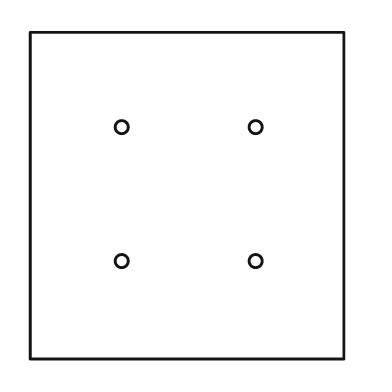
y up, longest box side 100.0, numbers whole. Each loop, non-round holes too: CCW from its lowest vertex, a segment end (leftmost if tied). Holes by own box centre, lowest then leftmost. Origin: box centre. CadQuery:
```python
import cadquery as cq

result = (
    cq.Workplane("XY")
    .moveTo(-48.0, -50.0)
    .lineTo(48.0, -50.0)
    .lineTo(48.0, 50.0)
    .lineTo(-48.0, 50.0)
    .close()
    .moveTo(-20.0, -20.0)
    .circle(2.0)
    .moveTo(21.0, -20.0)
    .circle(2.0)
    .moveTo(-20.0, 21.0)
    .circle(2.0)
    .moveTo(21.0, 21.0)
    .circle(2.0)
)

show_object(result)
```